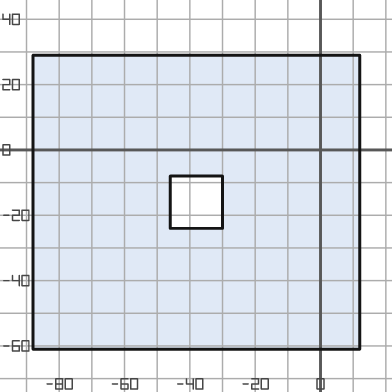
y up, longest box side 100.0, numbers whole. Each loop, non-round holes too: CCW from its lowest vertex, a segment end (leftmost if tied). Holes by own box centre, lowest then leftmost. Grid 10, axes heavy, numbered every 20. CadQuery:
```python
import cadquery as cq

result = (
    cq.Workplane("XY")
    .moveTo(-88.0, -61.0)
    .lineTo(12.0, -61.0)
    .lineTo(12.0, 29.0)
    .lineTo(-88.0, 29.0)
    .close()
    .moveTo(-46.0, -24.0)
    .lineTo(-30.0, -24.0)
    .lineTo(-30.0, -8.0)
    .lineTo(-46.0, -8.0)
    .close()
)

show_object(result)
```